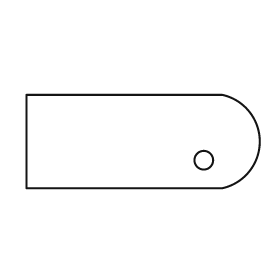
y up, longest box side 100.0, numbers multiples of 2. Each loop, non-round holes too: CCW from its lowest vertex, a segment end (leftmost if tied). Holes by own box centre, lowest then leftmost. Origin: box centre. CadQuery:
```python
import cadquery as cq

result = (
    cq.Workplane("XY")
    .moveTo(-50.0, -20.0)
    .lineTo(34.0, -20.0)
    .threePointArc((50.0, 0.0), (34.0, 20.0))
    .lineTo(-50.0, 20.0)
    .close()
    .moveTo(26.0, -8.0)
    .circle(4.0)
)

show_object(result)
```